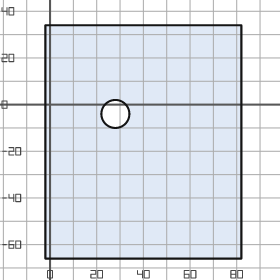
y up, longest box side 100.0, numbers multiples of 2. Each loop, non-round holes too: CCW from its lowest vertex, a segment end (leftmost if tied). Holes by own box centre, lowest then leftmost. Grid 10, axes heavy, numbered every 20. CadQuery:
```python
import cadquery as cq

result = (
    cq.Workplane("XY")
    .moveTo(-2.0, -66.0)
    .lineTo(82.0, -66.0)
    .lineTo(82.0, 34.0)
    .lineTo(-2.0, 34.0)
    .close()
    .moveTo(28.0, -4.0)
    .circle(6.0)
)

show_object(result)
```